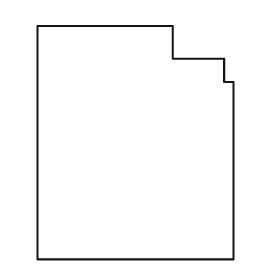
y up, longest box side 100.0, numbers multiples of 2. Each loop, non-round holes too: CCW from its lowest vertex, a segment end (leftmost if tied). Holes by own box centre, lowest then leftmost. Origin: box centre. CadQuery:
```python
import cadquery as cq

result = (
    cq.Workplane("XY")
    .moveTo(-42.0, -50.0)
    .lineTo(42.0, -50.0)
    .lineTo(42.0, 26.0)
    .lineTo(38.0, 26.0)
    .lineTo(38.0, 36.0)
    .lineTo(16.0, 36.0)
    .lineTo(16.0, 50.0)
    .lineTo(-42.0, 50.0)
    .close()
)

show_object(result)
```